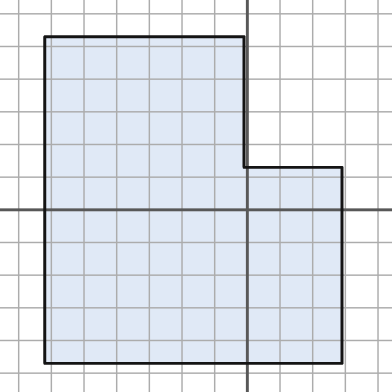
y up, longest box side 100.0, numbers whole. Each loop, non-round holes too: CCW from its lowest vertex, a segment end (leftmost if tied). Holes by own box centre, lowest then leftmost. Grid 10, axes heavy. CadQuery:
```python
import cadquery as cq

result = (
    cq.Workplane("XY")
    .moveTo(-62.0, -47.0)
    .lineTo(29.0, -47.0)
    .lineTo(29.0, 13.0)
    .lineTo(-1.0, 13.0)
    .lineTo(-1.0, 53.0)
    .lineTo(-62.0, 53.0)
    .close()
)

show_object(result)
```